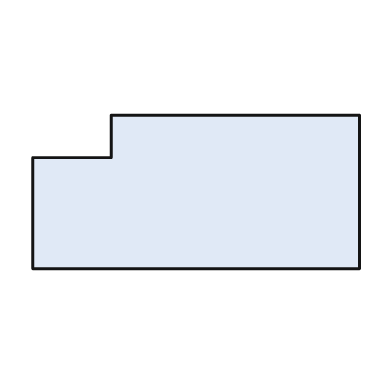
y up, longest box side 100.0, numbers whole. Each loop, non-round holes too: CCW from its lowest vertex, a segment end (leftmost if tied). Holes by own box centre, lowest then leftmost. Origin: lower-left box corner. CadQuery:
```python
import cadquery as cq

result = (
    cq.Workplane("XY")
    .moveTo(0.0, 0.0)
    .lineTo(100.0, 0.0)
    .lineTo(100.0, 47.0)
    .lineTo(24.0, 47.0)
    .lineTo(24.0, 34.0)
    .lineTo(0.0, 34.0)
    .close()
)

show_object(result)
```